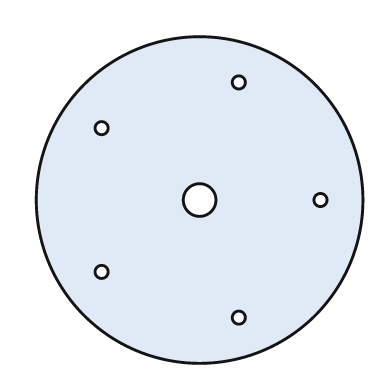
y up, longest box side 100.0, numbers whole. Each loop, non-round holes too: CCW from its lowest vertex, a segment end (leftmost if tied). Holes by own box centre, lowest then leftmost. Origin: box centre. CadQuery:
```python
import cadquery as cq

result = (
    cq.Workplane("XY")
    .moveTo(0.0, 0.0)
    .circle(50.0)
    .moveTo(12.0, -36.0)
    .circle(2.0)
    .moveTo(-30.0, -22.0)
    .circle(2.0)
    .moveTo(0.0, 0.0)
    .circle(5.0)
    .moveTo(37.0, 0.0)
    .circle(2.0)
    .moveTo(-30.0, 22.0)
    .circle(2.0)
    .moveTo(12.0, 36.0)
    .circle(2.0)
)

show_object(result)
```